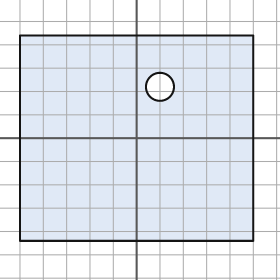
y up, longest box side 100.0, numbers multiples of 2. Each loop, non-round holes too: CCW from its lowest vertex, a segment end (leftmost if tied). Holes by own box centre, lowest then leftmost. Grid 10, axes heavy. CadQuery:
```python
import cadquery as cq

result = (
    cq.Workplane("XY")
    .moveTo(-50.0, -44.0)
    .lineTo(50.0, -44.0)
    .lineTo(50.0, 44.0)
    .lineTo(-50.0, 44.0)
    .close()
    .moveTo(10.0, 22.0)
    .circle(6.0)
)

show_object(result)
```